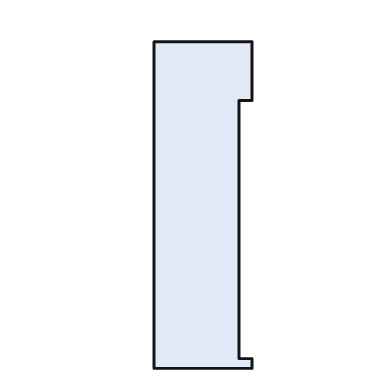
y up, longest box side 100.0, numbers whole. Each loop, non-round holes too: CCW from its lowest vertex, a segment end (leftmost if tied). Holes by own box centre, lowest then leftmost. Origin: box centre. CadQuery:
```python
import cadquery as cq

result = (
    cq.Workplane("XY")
    .moveTo(-15.0, -50.0)
    .lineTo(15.0, -50.0)
    .lineTo(15.0, -47.0)
    .lineTo(11.0, -47.0)
    .lineTo(11.0, 32.0)
    .lineTo(15.0, 32.0)
    .lineTo(15.0, 50.0)
    .lineTo(-15.0, 50.0)
    .close()
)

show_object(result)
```